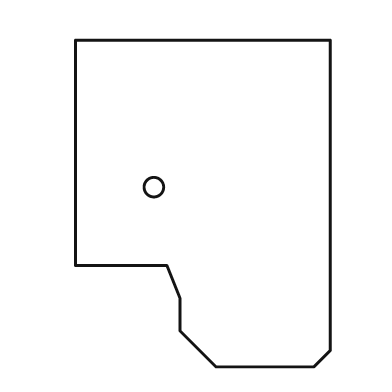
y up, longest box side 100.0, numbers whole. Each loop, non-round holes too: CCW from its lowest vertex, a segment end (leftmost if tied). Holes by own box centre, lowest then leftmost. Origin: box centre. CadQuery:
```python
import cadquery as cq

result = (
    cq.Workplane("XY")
    .moveTo(4.0, -50.0)
    .lineTo(34.0, -50.0)
    .lineTo(39.0, -45.0)
    .lineTo(39.0, 50.0)
    .lineTo(-39.0, 50.0)
    .lineTo(-39.0, -19.0)
    .lineTo(-11.0, -19.0)
    .lineTo(-7.0, -29.0)
    .lineTo(-7.0, -39.0)
    .close()
    .moveTo(-15.0, 5.0)
    .circle(3.0)
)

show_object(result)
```